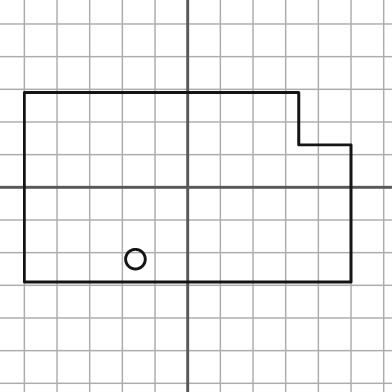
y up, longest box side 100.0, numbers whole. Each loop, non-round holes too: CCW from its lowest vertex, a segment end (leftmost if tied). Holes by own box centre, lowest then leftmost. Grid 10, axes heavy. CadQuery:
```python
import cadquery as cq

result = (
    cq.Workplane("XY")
    .moveTo(-50.0, -29.0)
    .lineTo(50.0, -29.0)
    .lineTo(50.0, 13.0)
    .lineTo(34.0, 13.0)
    .lineTo(34.0, 29.0)
    .lineTo(-50.0, 29.0)
    .close()
    .moveTo(-16.0, -22.0)
    .circle(3.0)
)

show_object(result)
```